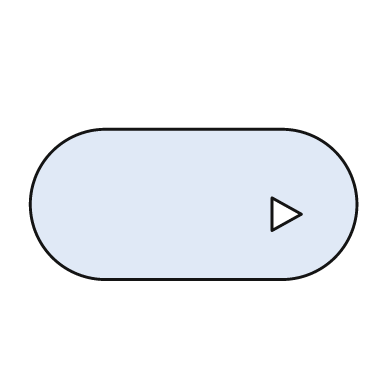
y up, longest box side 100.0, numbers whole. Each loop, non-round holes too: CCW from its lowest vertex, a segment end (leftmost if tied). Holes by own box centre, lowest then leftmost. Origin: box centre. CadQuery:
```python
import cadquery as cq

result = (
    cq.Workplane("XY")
    .moveTo(-27.0, -23.0)
    .lineTo(27.0, -23.0)
    .threePointArc((50.0, 0.0), (27.0, 23.0))
    .lineTo(-27.0, 23.0)
    .threePointArc((-50.0, 0.0), (-27.0, -23.0))
    .close()
    .moveTo(24.0, -8.0)
    .lineTo(33.0, -3.0)
    .lineTo(24.0, 2.0)
    .close()
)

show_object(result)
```